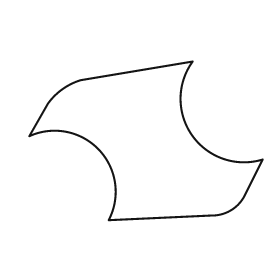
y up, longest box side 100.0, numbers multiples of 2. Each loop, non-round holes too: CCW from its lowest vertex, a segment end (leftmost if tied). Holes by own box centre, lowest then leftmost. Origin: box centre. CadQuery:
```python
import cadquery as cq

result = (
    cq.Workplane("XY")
    .moveTo(-16.0, -34.0)
    .lineTo(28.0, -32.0)
    .threePointArc((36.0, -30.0), (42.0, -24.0))
    .lineTo(50.0, -8.0)
    .threePointArc((20.0, 2.0), (20.0, 34.0))
    .lineTo(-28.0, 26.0)
    .threePointArc((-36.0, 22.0), (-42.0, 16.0))
    .lineTo(-50.0, 2.0)
    .threePointArc((-20.0, -4.0), (-16.0, -34.0))
    .close()
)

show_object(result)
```